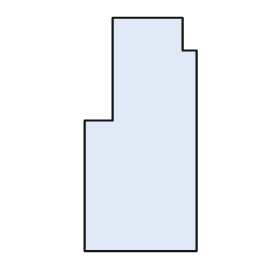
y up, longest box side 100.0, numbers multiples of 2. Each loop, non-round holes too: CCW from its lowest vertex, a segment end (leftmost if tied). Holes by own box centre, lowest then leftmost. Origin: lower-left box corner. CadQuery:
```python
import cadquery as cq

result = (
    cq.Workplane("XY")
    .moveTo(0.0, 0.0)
    .lineTo(48.0, 0.0)
    .lineTo(48.0, 86.0)
    .lineTo(42.0, 86.0)
    .lineTo(42.0, 100.0)
    .lineTo(12.0, 100.0)
    .lineTo(12.0, 56.0)
    .lineTo(0.0, 56.0)
    .close()
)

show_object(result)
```